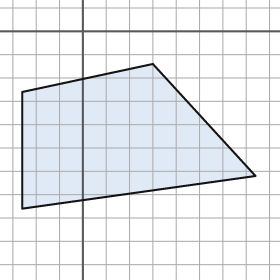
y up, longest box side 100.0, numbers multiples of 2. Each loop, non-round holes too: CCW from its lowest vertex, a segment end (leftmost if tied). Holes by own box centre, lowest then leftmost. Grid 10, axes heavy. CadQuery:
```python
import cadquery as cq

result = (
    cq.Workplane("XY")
    .moveTo(-26.0, -76.0)
    .lineTo(74.0, -62.0)
    .lineTo(30.0, -14.0)
    .lineTo(-26.0, -26.0)
    .close()
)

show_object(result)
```